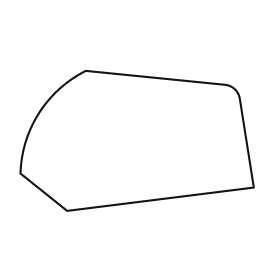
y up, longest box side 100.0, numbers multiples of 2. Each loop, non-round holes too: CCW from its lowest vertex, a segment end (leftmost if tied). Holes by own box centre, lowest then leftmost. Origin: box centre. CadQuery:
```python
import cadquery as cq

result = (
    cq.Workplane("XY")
    .moveTo(-30.0, -30.0)
    .lineTo(50.0, -20.0)
    .lineTo(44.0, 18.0)
    .threePointArc((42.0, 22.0), (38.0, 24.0))
    .lineTo(-22.0, 30.0)
    .threePointArc((-42.0, 12.0), (-50.0, -14.0))
    .close()
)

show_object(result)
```